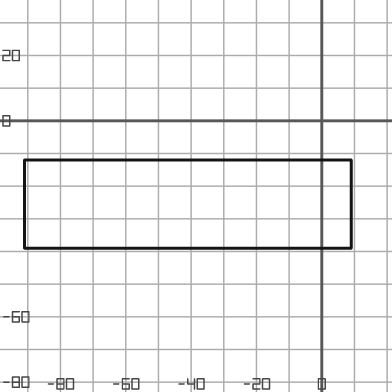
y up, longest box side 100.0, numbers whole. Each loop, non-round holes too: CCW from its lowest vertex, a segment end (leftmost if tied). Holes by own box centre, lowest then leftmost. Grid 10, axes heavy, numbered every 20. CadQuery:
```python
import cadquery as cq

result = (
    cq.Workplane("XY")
    .moveTo(-91.0, -39.0)
    .lineTo(9.0, -39.0)
    .lineTo(9.0, -12.0)
    .lineTo(-91.0, -12.0)
    .close()
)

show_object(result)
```